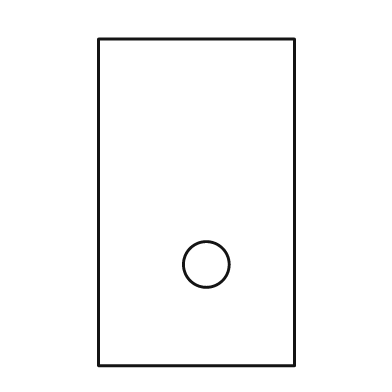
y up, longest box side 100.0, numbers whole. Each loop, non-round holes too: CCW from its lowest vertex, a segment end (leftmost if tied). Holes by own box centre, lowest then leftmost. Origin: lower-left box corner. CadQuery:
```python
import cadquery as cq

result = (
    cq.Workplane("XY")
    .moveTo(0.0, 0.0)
    .lineTo(60.0, 0.0)
    .lineTo(60.0, 100.0)
    .lineTo(0.0, 100.0)
    .close()
    .moveTo(33.0, 31.0)
    .circle(7.0)
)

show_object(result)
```